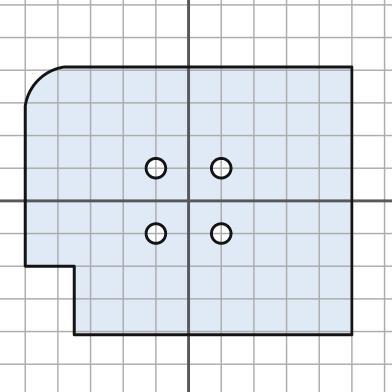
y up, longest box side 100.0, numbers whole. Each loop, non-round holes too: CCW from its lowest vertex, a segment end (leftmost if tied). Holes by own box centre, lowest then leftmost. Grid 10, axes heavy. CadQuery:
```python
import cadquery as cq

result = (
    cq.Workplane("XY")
    .moveTo(-35.0, -41.0)
    .lineTo(50.0, -41.0)
    .lineTo(50.0, 41.0)
    .lineTo(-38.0, 41.0)
    .threePointArc((-46.0, 37.0), (-50.0, 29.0))
    .lineTo(-50.0, -20.0)
    .lineTo(-35.0, -20.0)
    .close()
    .moveTo(-10.0, -10.0)
    .circle(3.0)
    .moveTo(10.0, -10.0)
    .circle(3.0)
    .moveTo(-10.0, 10.0)
    .circle(3.0)
    .moveTo(10.0, 10.0)
    .circle(3.0)
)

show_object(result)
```